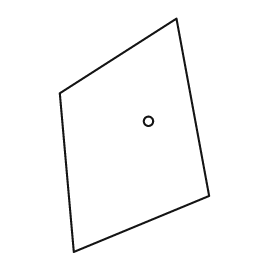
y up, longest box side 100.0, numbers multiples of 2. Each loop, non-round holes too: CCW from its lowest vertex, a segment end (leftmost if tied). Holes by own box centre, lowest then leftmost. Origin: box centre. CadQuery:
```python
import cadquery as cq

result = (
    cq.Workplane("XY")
    .moveTo(-26.0, -50.0)
    .lineTo(32.0, -26.0)
    .lineTo(18.0, 50.0)
    .lineTo(-32.0, 18.0)
    .close()
    .moveTo(6.0, 6.0)
    .circle(2.0)
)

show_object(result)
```